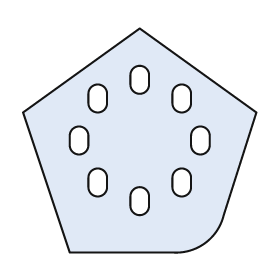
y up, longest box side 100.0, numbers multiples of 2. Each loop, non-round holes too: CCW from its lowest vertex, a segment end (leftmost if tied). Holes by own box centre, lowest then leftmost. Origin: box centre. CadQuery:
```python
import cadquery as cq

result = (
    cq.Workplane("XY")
    .moveTo(-30.0, -48.0)
    .lineTo(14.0, -48.0)
    .threePointArc((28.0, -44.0), (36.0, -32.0))
    .lineTo(50.0, 12.0)
    .lineTo(0.0, 48.0)
    .lineTo(-50.0, 12.0)
    .close()
    .moveTo(-4.0, -28.0)
    .threePointArc((0.0, -32.0), (4.0, -28.0))
    .lineTo(4.0, -24.0)
    .threePointArc((0.0, -20.0), (-4.0, -24.0))
    .close()
    .moveTo(-22.0, -20.0)
    .threePointArc((-18.0, -24.0), (-14.0, -20.0))
    .lineTo(-14.0, -16.0)
    .threePointArc((-18.0, -12.0), (-22.0, -16.0))
    .close()
    .moveTo(14.0, -20.0)
    .threePointArc((18.0, -24.0), (22.0, -20.0))
    .lineTo(22.0, -16.0)
    .threePointArc((18.0, -12.0), (14.0, -16.0))
    .close()
    .moveTo(-30.0, -2.0)
    .threePointArc((-26.0, -6.0), (-22.0, -2.0))
    .lineTo(-22.0, 2.0)
    .threePointArc((-26.0, 6.0), (-30.0, 2.0))
    .close()
    .moveTo(22.0, -2.0)
    .threePointArc((26.0, -6.0), (30.0, -2.0))
    .lineTo(30.0, 2.0)
    .threePointArc((26.0, 6.0), (22.0, 2.0))
    .close()
    .moveTo(-22.0, 16.0)
    .threePointArc((-18.0, 12.0), (-14.0, 16.0))
    .lineTo(-14.0, 20.0)
    .threePointArc((-18.0, 24.0), (-22.0, 20.0))
    .close()
    .moveTo(14.0, 16.0)
    .threePointArc((18.0, 12.0), (22.0, 16.0))
    .lineTo(22.0, 20.0)
    .threePointArc((18.0, 24.0), (14.0, 20.0))
    .close()
    .moveTo(-4.0, 24.0)
    .threePointArc((0.0, 20.0), (4.0, 24.0))
    .lineTo(4.0, 28.0)
    .threePointArc((0.0, 32.0), (-4.0, 28.0))
    .close()
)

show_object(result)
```